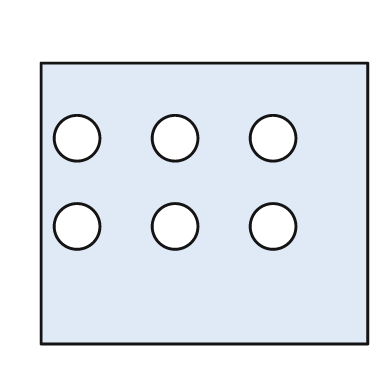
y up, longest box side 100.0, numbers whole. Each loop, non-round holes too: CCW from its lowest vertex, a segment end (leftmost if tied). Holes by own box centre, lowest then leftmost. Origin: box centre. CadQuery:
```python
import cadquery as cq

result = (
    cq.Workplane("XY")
    .moveTo(-50.0, -43.0)
    .lineTo(50.0, -43.0)
    .lineTo(50.0, 43.0)
    .lineTo(-50.0, 43.0)
    .close()
    .moveTo(-39.0, -7.0)
    .circle(7.0)
    .moveTo(-9.0, -7.0)
    .circle(7.0)
    .moveTo(21.0, -7.0)
    .circle(7.0)
    .moveTo(-39.0, 20.0)
    .circle(7.0)
    .moveTo(-9.0, 20.0)
    .circle(7.0)
    .moveTo(21.0, 20.0)
    .circle(7.0)
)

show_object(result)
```